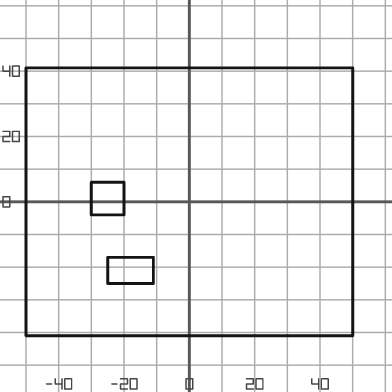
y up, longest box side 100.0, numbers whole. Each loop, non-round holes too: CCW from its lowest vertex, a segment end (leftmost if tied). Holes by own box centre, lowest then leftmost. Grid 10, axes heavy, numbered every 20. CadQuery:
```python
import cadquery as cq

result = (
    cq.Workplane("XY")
    .moveTo(-50.0, -41.0)
    .lineTo(50.0, -41.0)
    .lineTo(50.0, 41.0)
    .lineTo(-50.0, 41.0)
    .close()
    .moveTo(-25.0, -25.0)
    .lineTo(-11.0, -25.0)
    .lineTo(-11.0, -17.0)
    .lineTo(-25.0, -17.0)
    .close()
    .moveTo(-30.0, -4.0)
    .lineTo(-20.0, -4.0)
    .lineTo(-20.0, 6.0)
    .lineTo(-30.0, 6.0)
    .close()
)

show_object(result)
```